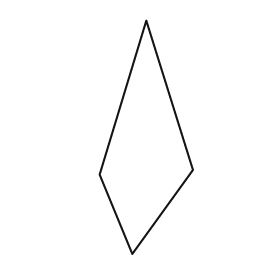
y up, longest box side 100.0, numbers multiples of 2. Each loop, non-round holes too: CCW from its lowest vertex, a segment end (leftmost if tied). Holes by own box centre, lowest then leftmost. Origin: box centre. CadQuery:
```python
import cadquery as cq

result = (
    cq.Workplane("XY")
    .moveTo(-6.0, -50.0)
    .lineTo(20.0, -14.0)
    .lineTo(0.0, 50.0)
    .lineTo(-20.0, -16.0)
    .close()
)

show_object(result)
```